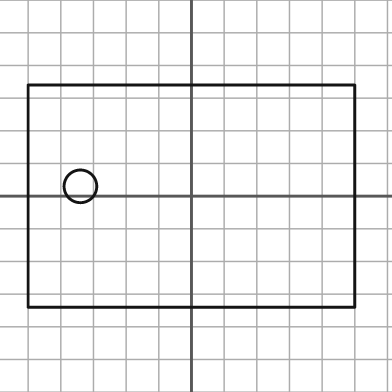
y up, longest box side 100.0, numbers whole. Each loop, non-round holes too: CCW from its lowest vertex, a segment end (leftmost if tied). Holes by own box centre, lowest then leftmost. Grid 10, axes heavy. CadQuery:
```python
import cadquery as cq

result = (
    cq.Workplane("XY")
    .moveTo(-50.0, -34.0)
    .lineTo(50.0, -34.0)
    .lineTo(50.0, 34.0)
    .lineTo(-50.0, 34.0)
    .close()
    .moveTo(-34.0, 3.0)
    .circle(5.0)
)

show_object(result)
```